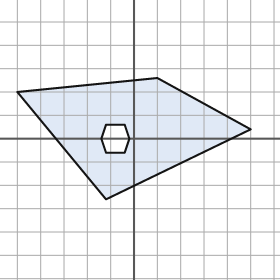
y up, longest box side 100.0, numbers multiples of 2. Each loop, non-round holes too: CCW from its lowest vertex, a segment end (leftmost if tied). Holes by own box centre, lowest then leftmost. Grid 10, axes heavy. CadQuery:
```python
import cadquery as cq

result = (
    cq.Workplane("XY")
    .moveTo(-12.0, -26.0)
    .lineTo(50.0, 4.0)
    .lineTo(10.0, 26.0)
    .lineTo(-50.0, 20.0)
    .close()
    .moveTo(-12.0, -6.0)
    .lineTo(-4.0, -6.0)
    .lineTo(-2.0, 0.0)
    .lineTo(-4.0, 6.0)
    .lineTo(-12.0, 6.0)
    .lineTo(-14.0, 0.0)
    .close()
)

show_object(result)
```